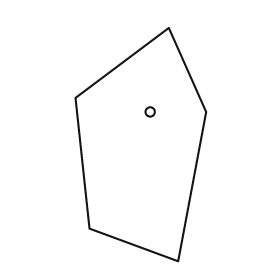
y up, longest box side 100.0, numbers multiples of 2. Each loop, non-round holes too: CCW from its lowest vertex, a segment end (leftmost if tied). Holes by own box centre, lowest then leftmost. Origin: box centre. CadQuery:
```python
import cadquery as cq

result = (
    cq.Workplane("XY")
    .moveTo(16.0, -50.0)
    .lineTo(28.0, 14.0)
    .lineTo(12.0, 50.0)
    .lineTo(-28.0, 20.0)
    .lineTo(-22.0, -36.0)
    .close()
    .moveTo(4.0, 14.0)
    .circle(2.0)
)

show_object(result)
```